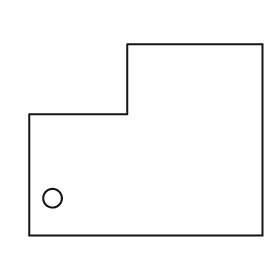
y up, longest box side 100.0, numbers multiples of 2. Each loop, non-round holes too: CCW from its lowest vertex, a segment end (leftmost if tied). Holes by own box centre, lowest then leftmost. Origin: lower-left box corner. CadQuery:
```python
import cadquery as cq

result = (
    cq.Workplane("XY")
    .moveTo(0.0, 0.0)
    .lineTo(100.0, 0.0)
    .lineTo(100.0, 82.0)
    .lineTo(42.0, 82.0)
    .lineTo(42.0, 52.0)
    .lineTo(0.0, 52.0)
    .close()
    .moveTo(10.0, 16.0)
    .circle(4.0)
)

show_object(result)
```